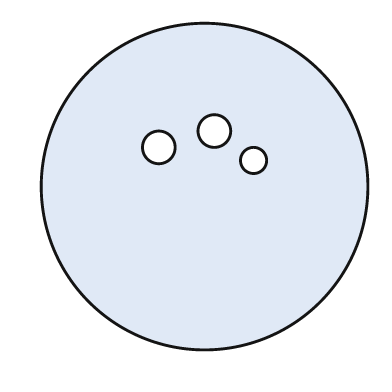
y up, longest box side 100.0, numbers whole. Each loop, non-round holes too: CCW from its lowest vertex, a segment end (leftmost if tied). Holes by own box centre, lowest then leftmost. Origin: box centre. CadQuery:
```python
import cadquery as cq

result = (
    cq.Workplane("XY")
    .moveTo(0.0, 0.0)
    .circle(50.0)
    .moveTo(15.0, 8.0)
    .circle(4.0)
    .moveTo(-14.0, 12.0)
    .circle(5.0)
    .moveTo(3.0, 17.0)
    .circle(5.0)
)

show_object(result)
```